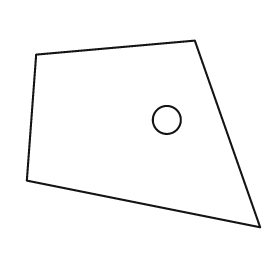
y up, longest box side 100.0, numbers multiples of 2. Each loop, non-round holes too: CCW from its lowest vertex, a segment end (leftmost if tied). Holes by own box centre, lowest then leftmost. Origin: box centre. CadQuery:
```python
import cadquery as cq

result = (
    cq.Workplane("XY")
    .moveTo(50.0, -40.0)
    .lineTo(22.0, 40.0)
    .lineTo(-46.0, 34.0)
    .lineTo(-50.0, -20.0)
    .close()
    .moveTo(10.0, 6.0)
    .circle(6.0)
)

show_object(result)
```